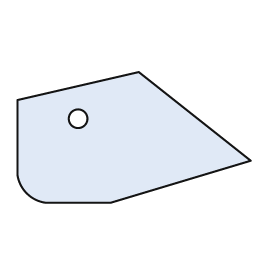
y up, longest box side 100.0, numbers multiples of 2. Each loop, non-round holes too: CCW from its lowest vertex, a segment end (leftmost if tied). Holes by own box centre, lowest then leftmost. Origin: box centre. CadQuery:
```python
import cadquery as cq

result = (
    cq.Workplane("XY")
    .moveTo(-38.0, -28.0)
    .lineTo(-10.0, -28.0)
    .lineTo(50.0, -10.0)
    .lineTo(2.0, 28.0)
    .lineTo(-50.0, 16.0)
    .lineTo(-50.0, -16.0)
    .threePointArc((-46.0, -24.0), (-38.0, -28.0))
    .close()
    .moveTo(-24.0, 8.0)
    .circle(4.0)
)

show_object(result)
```